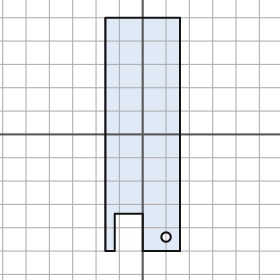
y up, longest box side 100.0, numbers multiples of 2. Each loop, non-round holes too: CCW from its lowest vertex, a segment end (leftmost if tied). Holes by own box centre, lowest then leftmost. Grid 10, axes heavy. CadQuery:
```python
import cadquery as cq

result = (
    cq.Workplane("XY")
    .moveTo(-16.0, -50.0)
    .lineTo(-12.0, -50.0)
    .lineTo(-12.0, -34.0)
    .lineTo(0.0, -34.0)
    .lineTo(0.0, -50.0)
    .lineTo(16.0, -50.0)
    .lineTo(16.0, 50.0)
    .lineTo(-16.0, 50.0)
    .close()
    .moveTo(10.0, -44.0)
    .circle(2.0)
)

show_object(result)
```